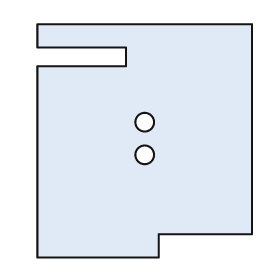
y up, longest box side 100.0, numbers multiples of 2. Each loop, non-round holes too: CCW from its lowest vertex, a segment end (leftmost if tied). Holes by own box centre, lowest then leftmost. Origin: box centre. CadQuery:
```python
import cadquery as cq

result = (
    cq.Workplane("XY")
    .moveTo(-46.0, -50.0)
    .lineTo(6.0, -50.0)
    .lineTo(6.0, -40.0)
    .lineTo(46.0, -40.0)
    .lineTo(46.0, 50.0)
    .lineTo(-46.0, 50.0)
    .lineTo(-46.0, 40.0)
    .lineTo(-8.0, 40.0)
    .lineTo(-8.0, 32.0)
    .lineTo(-46.0, 32.0)
    .close()
    .moveTo(0.0, -6.0)
    .circle(4.0)
    .moveTo(0.0, 8.0)
    .circle(4.0)
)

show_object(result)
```